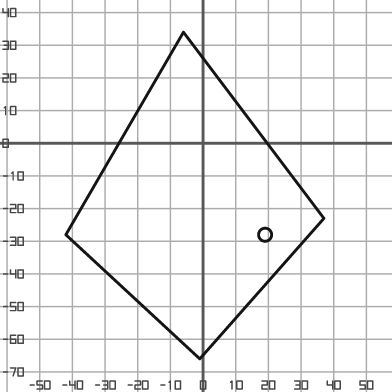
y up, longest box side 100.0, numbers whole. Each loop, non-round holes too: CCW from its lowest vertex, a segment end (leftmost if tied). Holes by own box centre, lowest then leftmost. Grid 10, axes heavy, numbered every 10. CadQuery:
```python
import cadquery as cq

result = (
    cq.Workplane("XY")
    .moveTo(-1.0, -66.0)
    .lineTo(37.0, -23.0)
    .lineTo(-6.0, 34.0)
    .lineTo(-42.0, -28.0)
    .close()
    .moveTo(19.0, -28.0)
    .circle(2.0)
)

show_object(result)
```